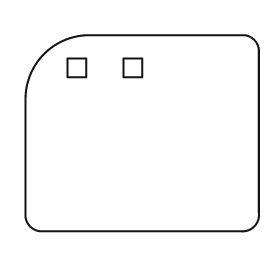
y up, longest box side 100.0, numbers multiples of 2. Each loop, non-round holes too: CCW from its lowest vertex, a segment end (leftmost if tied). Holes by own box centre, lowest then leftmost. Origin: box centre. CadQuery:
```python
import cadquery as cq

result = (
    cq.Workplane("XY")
    .moveTo(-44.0, -42.0)
    .lineTo(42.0, -42.0)
    .threePointArc((48.0, -40.0), (50.0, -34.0))
    .lineTo(50.0, 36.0)
    .threePointArc((48.0, 40.0), (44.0, 42.0))
    .lineTo(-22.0, 42.0)
    .threePointArc((-42.0, 34.0), (-50.0, 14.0))
    .lineTo(-50.0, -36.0)
    .threePointArc((-48.0, -40.0), (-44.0, -42.0))
    .close()
    .moveTo(-32.0, 24.0)
    .lineTo(-24.0, 24.0)
    .lineTo(-24.0, 32.0)
    .lineTo(-32.0, 32.0)
    .close()
    .moveTo(-8.0, 24.0)
    .lineTo(0.0, 24.0)
    .lineTo(0.0, 32.0)
    .lineTo(-8.0, 32.0)
    .close()
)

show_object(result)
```